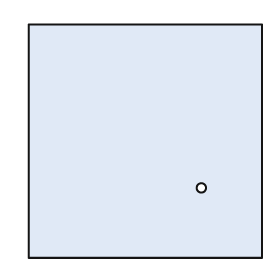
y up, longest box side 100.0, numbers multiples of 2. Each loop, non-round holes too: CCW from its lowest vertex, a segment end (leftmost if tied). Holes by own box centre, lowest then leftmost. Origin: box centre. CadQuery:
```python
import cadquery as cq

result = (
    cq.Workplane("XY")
    .moveTo(-50.0, -50.0)
    .lineTo(50.0, -50.0)
    .lineTo(50.0, 50.0)
    .lineTo(-50.0, 50.0)
    .close()
    .moveTo(24.0, -20.0)
    .circle(2.0)
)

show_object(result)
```